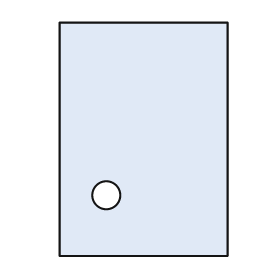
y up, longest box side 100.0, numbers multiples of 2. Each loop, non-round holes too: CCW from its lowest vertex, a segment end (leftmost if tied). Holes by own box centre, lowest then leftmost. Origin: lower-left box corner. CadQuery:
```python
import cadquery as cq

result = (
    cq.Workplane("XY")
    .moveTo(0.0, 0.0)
    .lineTo(72.0, 0.0)
    .lineTo(72.0, 100.0)
    .lineTo(0.0, 100.0)
    .close()
    .moveTo(20.0, 26.0)
    .circle(6.0)
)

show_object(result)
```